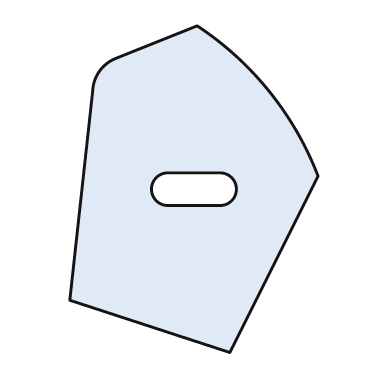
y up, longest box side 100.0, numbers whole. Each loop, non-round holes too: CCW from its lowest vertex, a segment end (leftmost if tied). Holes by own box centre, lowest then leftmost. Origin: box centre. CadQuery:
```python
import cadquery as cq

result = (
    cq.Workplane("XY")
    .moveTo(11.0, -50.0)
    .lineTo(38.0, 4.0)
    .threePointArc((23.0, 30.0), (1.0, 50.0))
    .lineTo(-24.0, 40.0)
    .threePointArc((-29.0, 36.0), (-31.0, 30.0))
    .lineTo(-38.0, -34.0)
    .close()
    .moveTo(-8.0, -5.0)
    .lineTo(8.0, -5.0)
    .threePointArc((13.0, 0.0), (8.0, 5.0))
    .lineTo(-8.0, 5.0)
    .threePointArc((-13.0, 0.0), (-8.0, -5.0))
    .close()
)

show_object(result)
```